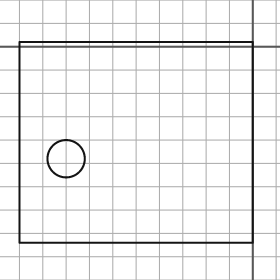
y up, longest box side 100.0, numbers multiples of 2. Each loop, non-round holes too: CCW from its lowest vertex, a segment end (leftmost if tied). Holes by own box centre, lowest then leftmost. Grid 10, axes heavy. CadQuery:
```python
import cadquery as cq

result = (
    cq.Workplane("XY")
    .moveTo(-100.0, -84.0)
    .lineTo(0.0, -84.0)
    .lineTo(0.0, 2.0)
    .lineTo(-100.0, 2.0)
    .close()
    .moveTo(-80.0, -48.0)
    .circle(8.0)
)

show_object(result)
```